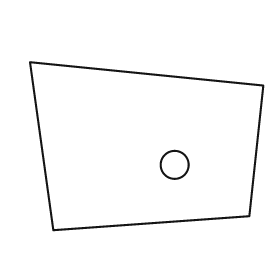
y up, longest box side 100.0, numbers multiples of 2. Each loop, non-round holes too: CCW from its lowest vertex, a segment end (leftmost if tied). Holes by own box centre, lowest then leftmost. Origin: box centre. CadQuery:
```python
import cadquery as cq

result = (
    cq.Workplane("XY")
    .moveTo(-40.0, -36.0)
    .lineTo(44.0, -30.0)
    .lineTo(50.0, 26.0)
    .lineTo(-50.0, 36.0)
    .close()
    .moveTo(12.0, -8.0)
    .circle(6.0)
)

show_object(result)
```